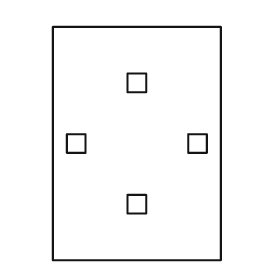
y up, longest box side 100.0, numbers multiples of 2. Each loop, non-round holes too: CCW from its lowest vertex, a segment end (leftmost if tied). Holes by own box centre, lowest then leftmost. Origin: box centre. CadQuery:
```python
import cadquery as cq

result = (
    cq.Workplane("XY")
    .moveTo(-36.0, -50.0)
    .lineTo(36.0, -50.0)
    .lineTo(36.0, 50.0)
    .lineTo(-36.0, 50.0)
    .close()
    .moveTo(-4.0, -30.0)
    .lineTo(4.0, -30.0)
    .lineTo(4.0, -22.0)
    .lineTo(-4.0, -22.0)
    .close()
    .moveTo(-30.0, -4.0)
    .lineTo(-22.0, -4.0)
    .lineTo(-22.0, 4.0)
    .lineTo(-30.0, 4.0)
    .close()
    .moveTo(22.0, -4.0)
    .lineTo(30.0, -4.0)
    .lineTo(30.0, 4.0)
    .lineTo(22.0, 4.0)
    .close()
    .moveTo(-4.0, 22.0)
    .lineTo(4.0, 22.0)
    .lineTo(4.0, 30.0)
    .lineTo(-4.0, 30.0)
    .close()
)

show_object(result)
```